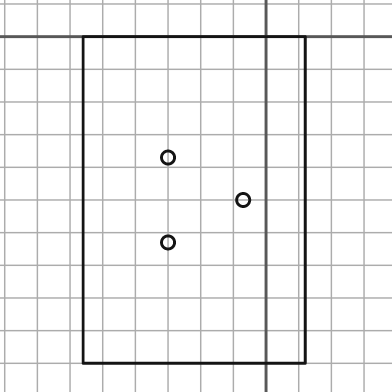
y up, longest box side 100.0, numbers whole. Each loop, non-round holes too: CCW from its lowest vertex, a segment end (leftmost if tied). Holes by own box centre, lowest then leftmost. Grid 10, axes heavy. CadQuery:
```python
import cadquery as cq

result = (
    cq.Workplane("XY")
    .moveTo(-56.0, -100.0)
    .lineTo(12.0, -100.0)
    .lineTo(12.0, 0.0)
    .lineTo(-56.0, 0.0)
    .close()
    .moveTo(-30.0, -63.0)
    .circle(2.0)
    .moveTo(-7.0, -50.0)
    .circle(2.0)
    .moveTo(-30.0, -37.0)
    .circle(2.0)
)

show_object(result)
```